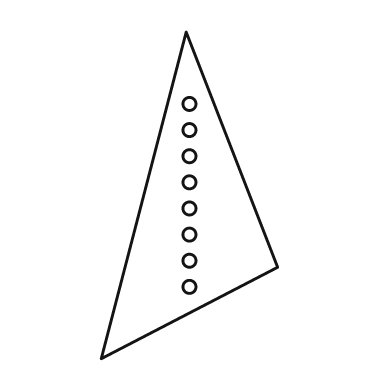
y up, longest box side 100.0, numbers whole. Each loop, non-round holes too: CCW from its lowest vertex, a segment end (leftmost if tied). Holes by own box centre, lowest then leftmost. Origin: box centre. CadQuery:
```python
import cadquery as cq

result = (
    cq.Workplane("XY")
    .moveTo(-27.0, -50.0)
    .lineTo(27.0, -22.0)
    .lineTo(-1.0, 50.0)
    .close()
    .moveTo(0.0, -28.0)
    .circle(2.0)
    .moveTo(0.0, -20.0)
    .circle(2.0)
    .moveTo(0.0, -12.0)
    .circle(2.0)
    .moveTo(0.0, -4.0)
    .circle(2.0)
    .moveTo(0.0, 4.0)
    .circle(2.0)
    .moveTo(0.0, 12.0)
    .circle(2.0)
    .moveTo(0.0, 20.0)
    .circle(2.0)
    .moveTo(0.0, 28.0)
    .circle(2.0)
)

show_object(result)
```